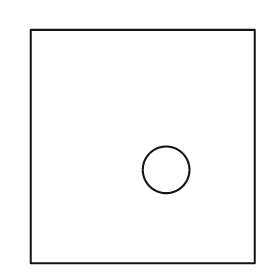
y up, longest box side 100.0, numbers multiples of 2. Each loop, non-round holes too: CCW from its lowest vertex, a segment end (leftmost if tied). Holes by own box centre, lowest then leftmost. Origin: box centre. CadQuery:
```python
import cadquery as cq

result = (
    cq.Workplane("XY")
    .moveTo(-48.0, -50.0)
    .lineTo(48.0, -50.0)
    .lineTo(48.0, 50.0)
    .lineTo(-48.0, 50.0)
    .close()
    .moveTo(10.0, -10.0)
    .circle(10.0)
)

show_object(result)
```